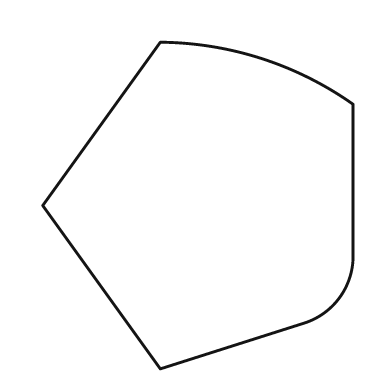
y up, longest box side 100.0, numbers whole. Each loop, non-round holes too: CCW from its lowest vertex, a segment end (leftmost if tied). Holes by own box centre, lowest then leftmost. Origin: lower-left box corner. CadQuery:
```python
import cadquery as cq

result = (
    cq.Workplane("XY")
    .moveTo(36.0, 0.0)
    .lineTo(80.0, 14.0)
    .threePointArc((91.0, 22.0), (95.0, 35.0))
    .lineTo(95.0, 81.0)
    .threePointArc((67.0, 95.0), (36.0, 100.0))
    .lineTo(0.0, 50.0)
    .close()
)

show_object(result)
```